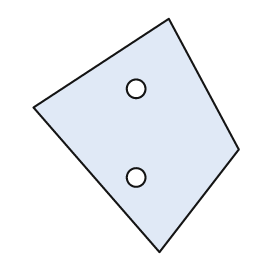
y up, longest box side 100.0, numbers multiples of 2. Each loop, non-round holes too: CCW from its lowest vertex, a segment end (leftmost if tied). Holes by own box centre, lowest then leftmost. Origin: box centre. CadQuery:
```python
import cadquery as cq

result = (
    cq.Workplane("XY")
    .moveTo(10.0, -50.0)
    .lineTo(44.0, -6.0)
    .lineTo(14.0, 50.0)
    .lineTo(-44.0, 12.0)
    .close()
    .moveTo(0.0, -18.0)
    .circle(4.0)
    .moveTo(0.0, 20.0)
    .circle(4.0)
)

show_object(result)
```